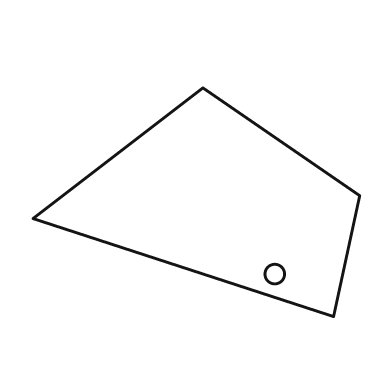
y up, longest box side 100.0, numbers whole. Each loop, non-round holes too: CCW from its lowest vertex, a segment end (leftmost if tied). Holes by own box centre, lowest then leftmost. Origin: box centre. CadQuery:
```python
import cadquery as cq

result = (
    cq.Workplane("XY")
    .moveTo(42.0, -35.0)
    .lineTo(50.0, 2.0)
    .lineTo(2.0, 35.0)
    .lineTo(-50.0, -5.0)
    .close()
    .moveTo(24.0, -22.0)
    .circle(3.0)
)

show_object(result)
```